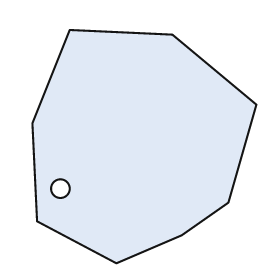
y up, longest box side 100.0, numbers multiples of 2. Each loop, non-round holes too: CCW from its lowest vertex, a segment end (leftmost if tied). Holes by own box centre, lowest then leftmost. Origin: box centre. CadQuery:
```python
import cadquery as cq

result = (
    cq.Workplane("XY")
    .moveTo(-12.0, -50.0)
    .lineTo(16.0, -38.0)
    .lineTo(36.0, -24.0)
    .lineTo(48.0, 18.0)
    .lineTo(12.0, 48.0)
    .lineTo(-32.0, 50.0)
    .lineTo(-48.0, 10.0)
    .lineTo(-46.0, -32.0)
    .close()
    .moveTo(-36.0, -18.0)
    .circle(4.0)
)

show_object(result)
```